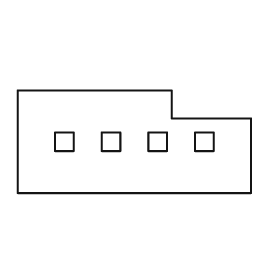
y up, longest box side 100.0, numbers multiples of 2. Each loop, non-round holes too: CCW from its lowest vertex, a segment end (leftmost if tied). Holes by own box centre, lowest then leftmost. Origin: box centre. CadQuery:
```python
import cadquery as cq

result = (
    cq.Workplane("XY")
    .moveTo(-50.0, -22.0)
    .lineTo(50.0, -22.0)
    .lineTo(50.0, 10.0)
    .lineTo(16.0, 10.0)
    .lineTo(16.0, 22.0)
    .lineTo(-50.0, 22.0)
    .close()
    .moveTo(-34.0, -4.0)
    .lineTo(-26.0, -4.0)
    .lineTo(-26.0, 4.0)
    .lineTo(-34.0, 4.0)
    .close()
    .moveTo(-14.0, -4.0)
    .lineTo(-6.0, -4.0)
    .lineTo(-6.0, 4.0)
    .lineTo(-14.0, 4.0)
    .close()
    .moveTo(6.0, -4.0)
    .lineTo(14.0, -4.0)
    .lineTo(14.0, 4.0)
    .lineTo(6.0, 4.0)
    .close()
    .moveTo(26.0, -4.0)
    .lineTo(34.0, -4.0)
    .lineTo(34.0, 4.0)
    .lineTo(26.0, 4.0)
    .close()
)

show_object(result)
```